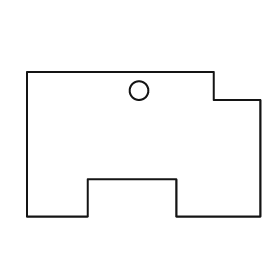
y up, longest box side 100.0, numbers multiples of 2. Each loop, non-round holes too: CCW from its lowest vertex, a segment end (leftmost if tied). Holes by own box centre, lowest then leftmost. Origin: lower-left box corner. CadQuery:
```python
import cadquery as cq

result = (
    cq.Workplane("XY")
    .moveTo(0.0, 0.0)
    .lineTo(26.0, 0.0)
    .lineTo(26.0, 16.0)
    .lineTo(64.0, 16.0)
    .lineTo(64.0, 0.0)
    .lineTo(100.0, 0.0)
    .lineTo(100.0, 50.0)
    .lineTo(80.0, 50.0)
    .lineTo(80.0, 62.0)
    .lineTo(0.0, 62.0)
    .close()
    .moveTo(48.0, 54.0)
    .circle(4.0)
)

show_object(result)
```